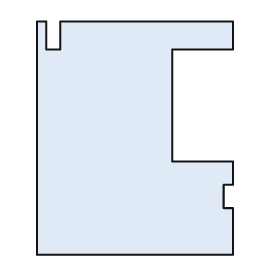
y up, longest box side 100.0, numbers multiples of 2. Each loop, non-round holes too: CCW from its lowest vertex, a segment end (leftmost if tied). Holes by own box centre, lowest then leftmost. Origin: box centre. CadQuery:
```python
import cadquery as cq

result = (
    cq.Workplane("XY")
    .moveTo(-42.0, -50.0)
    .lineTo(42.0, -50.0)
    .lineTo(42.0, -30.0)
    .lineTo(38.0, -30.0)
    .lineTo(38.0, -20.0)
    .lineTo(42.0, -20.0)
    .lineTo(42.0, -10.0)
    .lineTo(16.0, -10.0)
    .lineTo(16.0, 38.0)
    .lineTo(42.0, 38.0)
    .lineTo(42.0, 50.0)
    .lineTo(-32.0, 50.0)
    .lineTo(-32.0, 38.0)
    .lineTo(-38.0, 38.0)
    .lineTo(-38.0, 50.0)
    .lineTo(-42.0, 50.0)
    .close()
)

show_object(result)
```